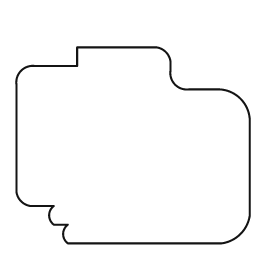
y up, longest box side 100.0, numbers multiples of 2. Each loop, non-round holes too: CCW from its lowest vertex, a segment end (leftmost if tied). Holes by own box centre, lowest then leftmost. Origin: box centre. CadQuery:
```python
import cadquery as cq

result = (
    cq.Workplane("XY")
    .moveTo(-28.0, -42.0)
    .lineTo(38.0, -42.0)
    .threePointArc((46.0, -38.0), (50.0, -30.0))
    .lineTo(50.0, 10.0)
    .threePointArc((46.0, 20.0), (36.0, 24.0))
    .lineTo(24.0, 24.0)
    .threePointArc((18.0, 26.0), (16.0, 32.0))
    .lineTo(16.0, 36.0)
    .threePointArc((14.0, 40.0), (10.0, 42.0))
    .lineTo(-24.0, 42.0)
    .lineTo(-24.0, 34.0)
    .lineTo(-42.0, 34.0)
    .threePointArc((-48.0, 32.0), (-50.0, 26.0))
    .lineTo(-50.0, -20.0)
    .threePointArc((-48.0, -24.0), (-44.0, -26.0))
    .lineTo(-34.0, -26.0)
    .threePointArc((-36.0, -30.0), (-34.0, -34.0))
    .lineTo(-28.0, -34.0)
    .threePointArc((-30.0, -38.0), (-28.0, -42.0))
    .close()
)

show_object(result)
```